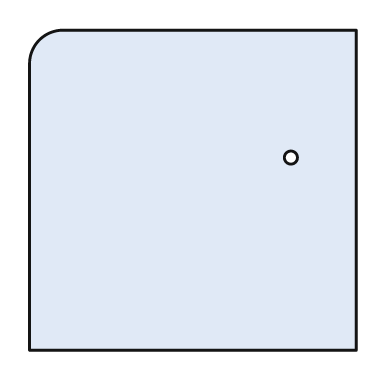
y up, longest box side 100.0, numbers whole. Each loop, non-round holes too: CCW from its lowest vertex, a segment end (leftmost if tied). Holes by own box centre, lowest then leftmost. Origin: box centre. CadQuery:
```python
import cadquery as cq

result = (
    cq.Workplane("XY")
    .moveTo(-50.0, -49.0)
    .lineTo(50.0, -49.0)
    .lineTo(50.0, 49.0)
    .lineTo(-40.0, 49.0)
    .threePointArc((-47.0, 46.0), (-50.0, 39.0))
    .close()
    .moveTo(30.0, 10.0)
    .circle(2.0)
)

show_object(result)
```